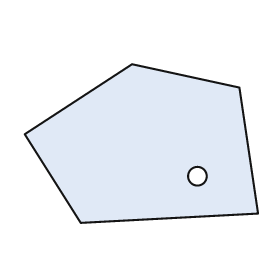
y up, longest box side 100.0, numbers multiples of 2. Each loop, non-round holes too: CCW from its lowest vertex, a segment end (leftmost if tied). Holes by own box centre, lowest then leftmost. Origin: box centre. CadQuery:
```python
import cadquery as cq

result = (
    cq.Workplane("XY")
    .moveTo(-26.0, -34.0)
    .lineTo(50.0, -30.0)
    .lineTo(42.0, 24.0)
    .lineTo(-4.0, 34.0)
    .lineTo(-50.0, 4.0)
    .close()
    .moveTo(24.0, -14.0)
    .circle(4.0)
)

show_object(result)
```